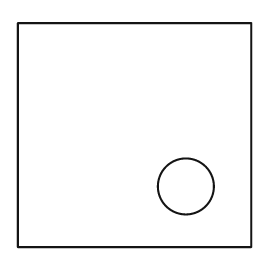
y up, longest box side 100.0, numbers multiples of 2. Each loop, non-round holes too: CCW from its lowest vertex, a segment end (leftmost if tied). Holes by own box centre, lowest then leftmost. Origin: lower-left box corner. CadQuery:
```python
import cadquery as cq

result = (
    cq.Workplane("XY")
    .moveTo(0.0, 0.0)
    .lineTo(100.0, 0.0)
    .lineTo(100.0, 96.0)
    .lineTo(0.0, 96.0)
    .close()
    .moveTo(72.0, 26.0)
    .circle(12.0)
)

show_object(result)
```